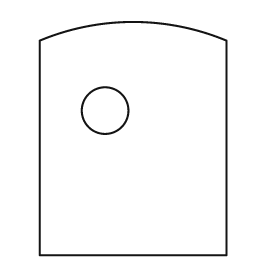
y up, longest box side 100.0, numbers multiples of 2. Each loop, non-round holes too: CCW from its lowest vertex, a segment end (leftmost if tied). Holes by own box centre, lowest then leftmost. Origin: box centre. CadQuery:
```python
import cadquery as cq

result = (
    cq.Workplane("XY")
    .moveTo(-40.0, -50.0)
    .lineTo(40.0, -50.0)
    .lineTo(40.0, 42.0)
    .threePointArc((0.0, 50.0), (-40.0, 42.0))
    .close()
    .moveTo(-12.0, 12.0)
    .circle(10.0)
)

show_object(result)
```